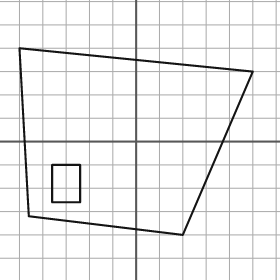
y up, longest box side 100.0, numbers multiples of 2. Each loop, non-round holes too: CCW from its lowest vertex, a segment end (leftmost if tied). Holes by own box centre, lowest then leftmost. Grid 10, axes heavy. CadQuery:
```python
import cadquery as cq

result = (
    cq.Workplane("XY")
    .moveTo(20.0, -40.0)
    .lineTo(50.0, 30.0)
    .lineTo(-50.0, 40.0)
    .lineTo(-46.0, -32.0)
    .close()
    .moveTo(-36.0, -26.0)
    .lineTo(-24.0, -26.0)
    .lineTo(-24.0, -10.0)
    .lineTo(-36.0, -10.0)
    .close()
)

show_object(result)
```